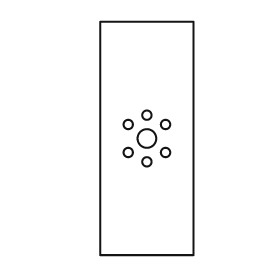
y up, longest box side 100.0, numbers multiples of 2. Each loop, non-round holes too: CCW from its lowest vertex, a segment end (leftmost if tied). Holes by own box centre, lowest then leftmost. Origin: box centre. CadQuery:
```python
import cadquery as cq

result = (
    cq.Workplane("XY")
    .moveTo(-20.0, -50.0)
    .lineTo(20.0, -50.0)
    .lineTo(20.0, 50.0)
    .lineTo(-20.0, 50.0)
    .close()
    .moveTo(0.0, -10.0)
    .circle(2.0)
    .moveTo(-8.0, -6.0)
    .circle(2.0)
    .moveTo(8.0, -6.0)
    .circle(2.0)
    .moveTo(0.0, 0.0)
    .circle(4.0)
    .moveTo(-8.0, 6.0)
    .circle(2.0)
    .moveTo(8.0, 6.0)
    .circle(2.0)
    .moveTo(0.0, 10.0)
    .circle(2.0)
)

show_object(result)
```